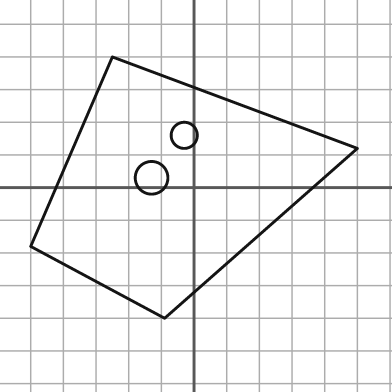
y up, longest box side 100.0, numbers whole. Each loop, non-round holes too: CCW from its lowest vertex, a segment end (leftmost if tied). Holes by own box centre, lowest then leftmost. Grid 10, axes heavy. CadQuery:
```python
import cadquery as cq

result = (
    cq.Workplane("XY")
    .moveTo(-9.0, -40.0)
    .lineTo(50.0, 12.0)
    .lineTo(-25.0, 40.0)
    .lineTo(-50.0, -18.0)
    .close()
    .moveTo(-13.0, 3.0)
    .circle(5.0)
    .moveTo(-3.0, 16.0)
    .circle(4.0)
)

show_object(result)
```